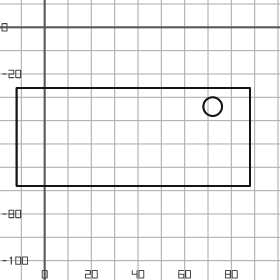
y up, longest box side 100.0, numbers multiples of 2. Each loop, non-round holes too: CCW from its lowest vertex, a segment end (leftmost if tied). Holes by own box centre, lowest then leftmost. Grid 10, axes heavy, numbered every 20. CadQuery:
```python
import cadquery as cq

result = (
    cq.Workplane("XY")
    .moveTo(-12.0, -68.0)
    .lineTo(88.0, -68.0)
    .lineTo(88.0, -26.0)
    .lineTo(-12.0, -26.0)
    .close()
    .moveTo(72.0, -34.0)
    .circle(4.0)
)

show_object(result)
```